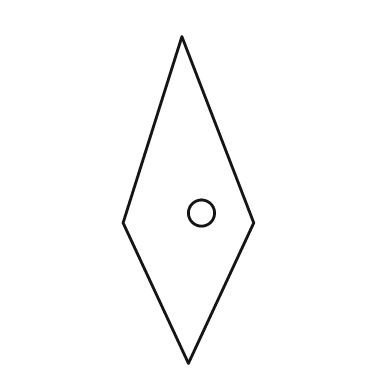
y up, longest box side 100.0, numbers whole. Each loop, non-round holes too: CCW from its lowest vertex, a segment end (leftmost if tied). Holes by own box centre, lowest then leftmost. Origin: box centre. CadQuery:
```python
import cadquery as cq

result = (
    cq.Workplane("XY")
    .moveTo(0.0, -50.0)
    .lineTo(20.0, -7.0)
    .lineTo(-2.0, 50.0)
    .lineTo(-20.0, -7.0)
    .close()
    .moveTo(4.0, -4.0)
    .circle(4.0)
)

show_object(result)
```